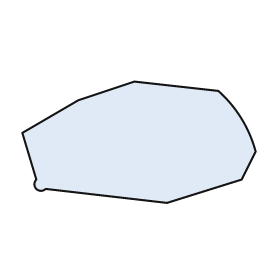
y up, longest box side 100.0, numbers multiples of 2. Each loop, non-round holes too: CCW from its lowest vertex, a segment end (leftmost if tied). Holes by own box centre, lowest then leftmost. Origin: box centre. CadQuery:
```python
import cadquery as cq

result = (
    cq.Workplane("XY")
    .moveTo(12.0, -26.0)
    .lineTo(44.0, -16.0)
    .lineTo(50.0, -4.0)
    .threePointArc((44.0, 10.0), (34.0, 22.0))
    .lineTo(-2.0, 26.0)
    .lineTo(-26.0, 18.0)
    .lineTo(-50.0, 4.0)
    .lineTo(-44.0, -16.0)
    .threePointArc((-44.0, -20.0), (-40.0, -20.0))
    .close()
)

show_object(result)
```